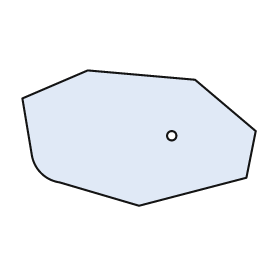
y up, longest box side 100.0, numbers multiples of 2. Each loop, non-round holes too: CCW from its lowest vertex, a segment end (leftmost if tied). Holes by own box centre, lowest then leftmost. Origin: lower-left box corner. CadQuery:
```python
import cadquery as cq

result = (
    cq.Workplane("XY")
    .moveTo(50.0, 0.0)
    .lineTo(96.0, 12.0)
    .lineTo(100.0, 32.0)
    .lineTo(74.0, 54.0)
    .lineTo(28.0, 58.0)
    .lineTo(0.0, 46.0)
    .lineTo(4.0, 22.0)
    .threePointArc((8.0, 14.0), (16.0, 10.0))
    .close()
    .moveTo(64.0, 30.0)
    .circle(2.0)
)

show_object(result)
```